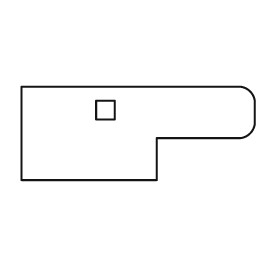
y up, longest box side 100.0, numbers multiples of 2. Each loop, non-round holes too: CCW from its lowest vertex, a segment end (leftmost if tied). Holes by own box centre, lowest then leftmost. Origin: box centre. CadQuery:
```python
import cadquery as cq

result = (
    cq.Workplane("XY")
    .moveTo(-50.0, -20.0)
    .lineTo(8.0, -20.0)
    .lineTo(8.0, -2.0)
    .lineTo(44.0, -2.0)
    .threePointArc((48.0, 0.0), (50.0, 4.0))
    .lineTo(50.0, 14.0)
    .threePointArc((48.0, 18.0), (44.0, 20.0))
    .lineTo(-50.0, 20.0)
    .close()
    .moveTo(-18.0, 6.0)
    .lineTo(-10.0, 6.0)
    .lineTo(-10.0, 14.0)
    .lineTo(-18.0, 14.0)
    .close()
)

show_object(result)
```